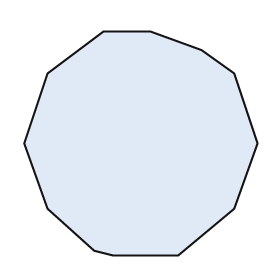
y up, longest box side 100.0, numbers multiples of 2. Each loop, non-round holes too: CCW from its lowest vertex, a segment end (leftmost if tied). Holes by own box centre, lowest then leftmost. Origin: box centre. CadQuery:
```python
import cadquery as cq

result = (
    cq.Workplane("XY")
    .moveTo(-12.0, -48.0)
    .lineTo(16.0, -48.0)
    .lineTo(40.0, -28.0)
    .lineTo(50.0, 0.0)
    .lineTo(40.0, 30.0)
    .lineTo(26.0, 40.0)
    .lineTo(4.0, 48.0)
    .lineTo(-16.0, 48.0)
    .lineTo(-40.0, 30.0)
    .lineTo(-50.0, 0.0)
    .lineTo(-40.0, -28.0)
    .lineTo(-20.0, -46.0)
    .close()
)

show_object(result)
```